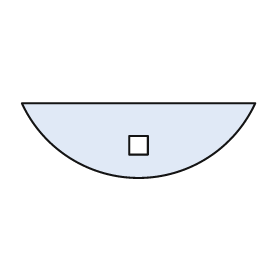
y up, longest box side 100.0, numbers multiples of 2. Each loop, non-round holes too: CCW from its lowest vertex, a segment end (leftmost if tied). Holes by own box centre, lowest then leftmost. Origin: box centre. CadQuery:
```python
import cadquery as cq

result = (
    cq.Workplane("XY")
    .moveTo(-50.0, 16.0)
    .threePointArc((0.0, -16.0), (50.0, 16.0))
    .close()
    .moveTo(-4.0, -6.0)
    .lineTo(4.0, -6.0)
    .lineTo(4.0, 2.0)
    .lineTo(-4.0, 2.0)
    .close()
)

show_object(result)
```